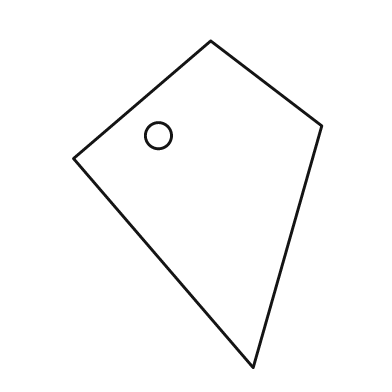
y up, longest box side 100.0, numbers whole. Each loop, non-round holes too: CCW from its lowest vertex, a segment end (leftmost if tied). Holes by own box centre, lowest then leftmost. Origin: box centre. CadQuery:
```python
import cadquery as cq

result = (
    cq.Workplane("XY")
    .moveTo(17.0, -50.0)
    .lineTo(38.0, 24.0)
    .lineTo(4.0, 50.0)
    .lineTo(-38.0, 14.0)
    .close()
    .moveTo(-12.0, 21.0)
    .circle(4.0)
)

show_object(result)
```